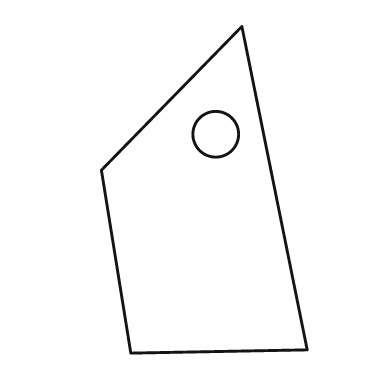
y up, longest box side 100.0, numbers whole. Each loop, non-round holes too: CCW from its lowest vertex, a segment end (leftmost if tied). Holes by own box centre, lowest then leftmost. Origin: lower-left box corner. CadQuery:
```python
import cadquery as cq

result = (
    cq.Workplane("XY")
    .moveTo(9.0, 0.0)
    .lineTo(63.0, 1.0)
    .lineTo(43.0, 100.0)
    .lineTo(0.0, 56.0)
    .close()
    .moveTo(35.0, 67.0)
    .circle(7.0)
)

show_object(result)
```